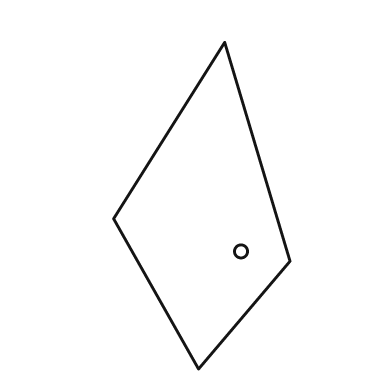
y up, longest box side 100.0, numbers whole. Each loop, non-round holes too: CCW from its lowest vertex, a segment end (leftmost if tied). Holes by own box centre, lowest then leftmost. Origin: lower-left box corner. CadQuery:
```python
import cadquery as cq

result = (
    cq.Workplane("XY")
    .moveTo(26.0, 0.0)
    .lineTo(54.0, 33.0)
    .lineTo(34.0, 100.0)
    .lineTo(0.0, 46.0)
    .close()
    .moveTo(39.0, 36.0)
    .circle(2.0)
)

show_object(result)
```